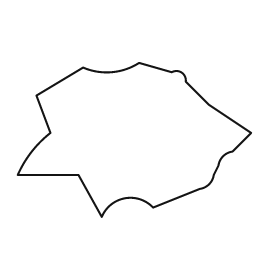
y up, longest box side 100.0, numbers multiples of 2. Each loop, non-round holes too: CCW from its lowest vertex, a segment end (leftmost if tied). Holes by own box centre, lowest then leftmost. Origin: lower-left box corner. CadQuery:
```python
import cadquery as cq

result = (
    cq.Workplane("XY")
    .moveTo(36.0, 0.0)
    .threePointArc((46.0, 8.0), (58.0, 4.0))
    .lineTo(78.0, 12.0)
    .threePointArc((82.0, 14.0), (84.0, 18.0))
    .lineTo(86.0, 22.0)
    .threePointArc((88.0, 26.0), (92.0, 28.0))
    .lineTo(100.0, 36.0)
    .lineTo(82.0, 48.0)
    .lineTo(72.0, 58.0)
    .threePointArc((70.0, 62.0), (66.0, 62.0))
    .lineTo(52.0, 66.0)
    .threePointArc((40.0, 62.0), (28.0, 64.0))
    .lineTo(8.0, 52.0)
    .lineTo(14.0, 36.0)
    .threePointArc((6.0, 28.0), (0.0, 18.0))
    .lineTo(26.0, 18.0)
    .close()
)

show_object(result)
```